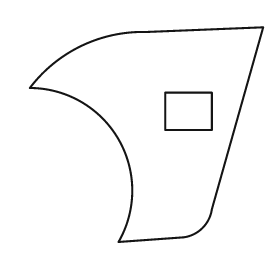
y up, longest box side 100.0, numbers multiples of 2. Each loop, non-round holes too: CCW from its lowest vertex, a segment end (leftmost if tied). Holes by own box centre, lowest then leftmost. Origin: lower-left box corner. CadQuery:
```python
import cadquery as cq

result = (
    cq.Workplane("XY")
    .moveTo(38.0, 0.0)
    .lineTo(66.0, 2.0)
    .threePointArc((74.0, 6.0), (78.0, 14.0))
    .lineTo(100.0, 92.0)
    .lineTo(50.0, 90.0)
    .threePointArc((22.0, 84.0), (0.0, 66.0))
    .threePointArc((38.0, 44.0), (38.0, 0.0))
    .close()
    .moveTo(58.0, 48.0)
    .lineTo(78.0, 48.0)
    .lineTo(78.0, 64.0)
    .lineTo(58.0, 64.0)
    .close()
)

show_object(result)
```